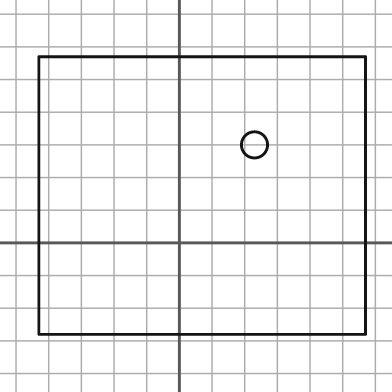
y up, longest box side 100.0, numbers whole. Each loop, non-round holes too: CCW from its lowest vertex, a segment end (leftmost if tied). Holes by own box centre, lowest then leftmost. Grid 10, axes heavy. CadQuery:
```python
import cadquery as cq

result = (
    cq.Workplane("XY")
    .moveTo(-43.0, -28.0)
    .lineTo(57.0, -28.0)
    .lineTo(57.0, 57.0)
    .lineTo(-43.0, 57.0)
    .close()
    .moveTo(23.0, 30.0)
    .circle(4.0)
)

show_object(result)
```